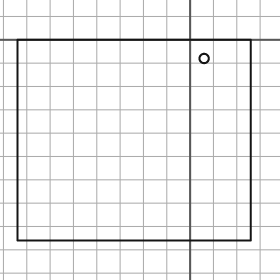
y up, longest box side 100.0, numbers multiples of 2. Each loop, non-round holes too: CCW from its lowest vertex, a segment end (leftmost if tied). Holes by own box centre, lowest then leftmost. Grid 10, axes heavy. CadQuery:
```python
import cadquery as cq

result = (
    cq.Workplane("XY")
    .moveTo(-74.0, -86.0)
    .lineTo(26.0, -86.0)
    .lineTo(26.0, 0.0)
    .lineTo(-74.0, 0.0)
    .close()
    .moveTo(6.0, -8.0)
    .circle(2.0)
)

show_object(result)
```